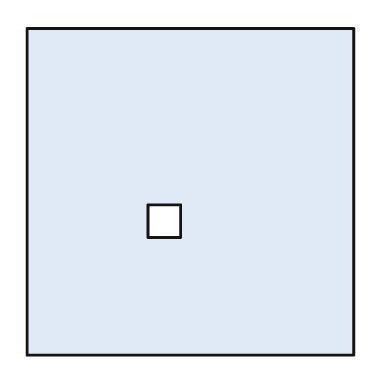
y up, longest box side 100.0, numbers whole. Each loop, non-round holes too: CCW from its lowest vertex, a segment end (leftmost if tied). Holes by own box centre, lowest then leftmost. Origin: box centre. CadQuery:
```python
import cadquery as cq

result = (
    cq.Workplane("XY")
    .moveTo(-50.0, -50.0)
    .lineTo(50.0, -50.0)
    .lineTo(50.0, 50.0)
    .lineTo(-50.0, 50.0)
    .close()
    .moveTo(-13.0, -14.0)
    .lineTo(-3.0, -14.0)
    .lineTo(-3.0, -4.0)
    .lineTo(-13.0, -4.0)
    .close()
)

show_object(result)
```